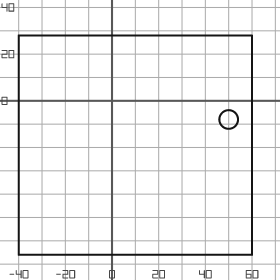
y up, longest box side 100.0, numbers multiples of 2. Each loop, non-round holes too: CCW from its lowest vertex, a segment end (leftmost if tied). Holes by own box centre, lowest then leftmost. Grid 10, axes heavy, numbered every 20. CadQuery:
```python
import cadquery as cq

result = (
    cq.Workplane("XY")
    .moveTo(-40.0, -66.0)
    .lineTo(60.0, -66.0)
    .lineTo(60.0, 28.0)
    .lineTo(-40.0, 28.0)
    .close()
    .moveTo(50.0, -8.0)
    .circle(4.0)
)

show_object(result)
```